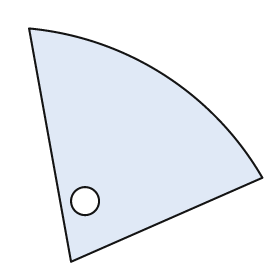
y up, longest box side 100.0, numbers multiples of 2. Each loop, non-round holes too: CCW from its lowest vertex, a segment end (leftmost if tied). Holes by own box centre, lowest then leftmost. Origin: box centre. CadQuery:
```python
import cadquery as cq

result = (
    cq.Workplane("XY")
    .moveTo(-32.0, -50.0)
    .lineTo(50.0, -14.0)
    .threePointArc((8.0, 30.0), (-50.0, 50.0))
    .close()
    .moveTo(-26.0, -24.0)
    .circle(6.0)
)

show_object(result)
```